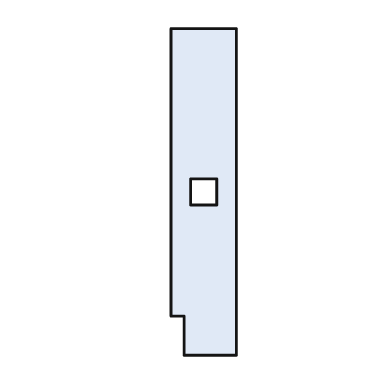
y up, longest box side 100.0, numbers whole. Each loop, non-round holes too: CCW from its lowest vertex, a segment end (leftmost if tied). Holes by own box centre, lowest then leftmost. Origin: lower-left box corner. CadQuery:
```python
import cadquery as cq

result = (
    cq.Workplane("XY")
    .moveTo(4.0, 0.0)
    .lineTo(20.0, 0.0)
    .lineTo(20.0, 100.0)
    .lineTo(0.0, 100.0)
    .lineTo(0.0, 12.0)
    .lineTo(4.0, 12.0)
    .close()
    .moveTo(6.0, 46.0)
    .lineTo(14.0, 46.0)
    .lineTo(14.0, 54.0)
    .lineTo(6.0, 54.0)
    .close()
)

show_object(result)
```